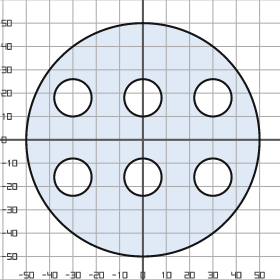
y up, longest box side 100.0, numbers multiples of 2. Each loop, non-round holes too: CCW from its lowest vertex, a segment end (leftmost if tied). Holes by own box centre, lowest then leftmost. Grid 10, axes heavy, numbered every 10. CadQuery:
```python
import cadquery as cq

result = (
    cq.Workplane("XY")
    .moveTo(0.0, 0.0)
    .circle(50.0)
    .moveTo(-30.0, -16.0)
    .circle(8.0)
    .moveTo(0.0, -16.0)
    .circle(8.0)
    .moveTo(30.0, -16.0)
    .circle(8.0)
    .moveTo(-30.0, 18.0)
    .circle(8.0)
    .moveTo(0.0, 18.0)
    .circle(8.0)
    .moveTo(30.0, 18.0)
    .circle(8.0)
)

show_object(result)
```